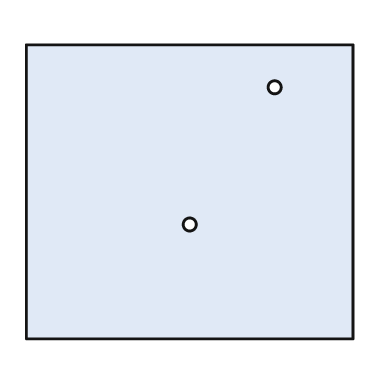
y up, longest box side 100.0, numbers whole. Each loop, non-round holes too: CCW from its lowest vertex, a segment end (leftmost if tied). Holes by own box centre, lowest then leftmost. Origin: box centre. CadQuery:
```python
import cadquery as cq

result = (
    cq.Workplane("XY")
    .moveTo(-50.0, -45.0)
    .lineTo(50.0, -45.0)
    .lineTo(50.0, 45.0)
    .lineTo(-50.0, 45.0)
    .close()
    .moveTo(0.0, -10.0)
    .circle(2.0)
    .moveTo(26.0, 32.0)
    .circle(2.0)
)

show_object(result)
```